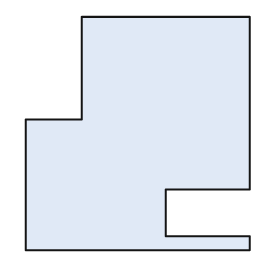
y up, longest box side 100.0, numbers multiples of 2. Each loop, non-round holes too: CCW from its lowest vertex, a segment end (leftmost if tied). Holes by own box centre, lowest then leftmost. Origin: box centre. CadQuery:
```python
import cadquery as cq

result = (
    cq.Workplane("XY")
    .moveTo(-48.0, -50.0)
    .lineTo(48.0, -50.0)
    .lineTo(48.0, -44.0)
    .lineTo(12.0, -44.0)
    .lineTo(12.0, -24.0)
    .lineTo(48.0, -24.0)
    .lineTo(48.0, 50.0)
    .lineTo(-24.0, 50.0)
    .lineTo(-24.0, 6.0)
    .lineTo(-48.0, 6.0)
    .close()
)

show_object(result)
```